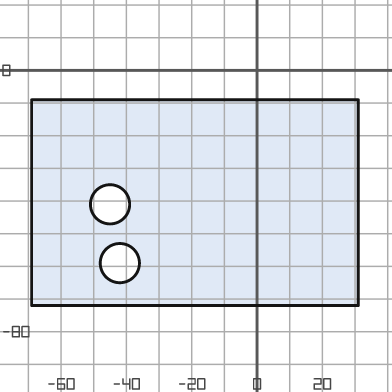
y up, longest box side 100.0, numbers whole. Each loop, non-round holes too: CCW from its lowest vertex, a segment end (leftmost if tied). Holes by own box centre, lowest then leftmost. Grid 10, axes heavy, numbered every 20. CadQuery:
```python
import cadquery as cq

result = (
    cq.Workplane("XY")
    .moveTo(-69.0, -72.0)
    .lineTo(31.0, -72.0)
    .lineTo(31.0, -9.0)
    .lineTo(-69.0, -9.0)
    .close()
    .moveTo(-42.0, -59.0)
    .circle(6.0)
    .moveTo(-45.0, -41.0)
    .circle(6.0)
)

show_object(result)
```